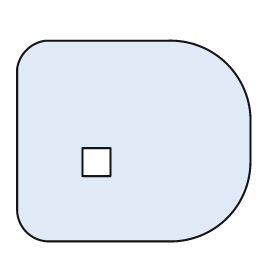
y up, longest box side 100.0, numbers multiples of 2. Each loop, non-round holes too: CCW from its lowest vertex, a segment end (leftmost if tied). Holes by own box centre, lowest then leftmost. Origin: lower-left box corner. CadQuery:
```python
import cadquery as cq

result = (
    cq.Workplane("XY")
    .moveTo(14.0, 0.0)
    .lineTo(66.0, 0.0)
    .threePointArc((90.0, 10.0), (100.0, 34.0))
    .lineTo(100.0, 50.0)
    .threePointArc((90.0, 76.0), (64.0, 86.0))
    .lineTo(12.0, 86.0)
    .threePointArc((4.0, 82.0), (0.0, 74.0))
    .lineTo(0.0, 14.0)
    .threePointArc((4.0, 4.0), (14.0, 0.0))
    .close()
    .moveTo(28.0, 28.0)
    .lineTo(40.0, 28.0)
    .lineTo(40.0, 40.0)
    .lineTo(28.0, 40.0)
    .close()
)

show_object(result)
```